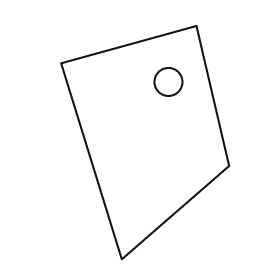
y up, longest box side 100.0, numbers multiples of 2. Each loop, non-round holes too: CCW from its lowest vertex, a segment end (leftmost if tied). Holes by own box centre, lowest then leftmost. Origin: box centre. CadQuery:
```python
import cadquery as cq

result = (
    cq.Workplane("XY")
    .moveTo(-10.0, -50.0)
    .lineTo(36.0, -10.0)
    .lineTo(22.0, 50.0)
    .lineTo(-36.0, 34.0)
    .close()
    .moveTo(10.0, 26.0)
    .circle(6.0)
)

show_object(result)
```